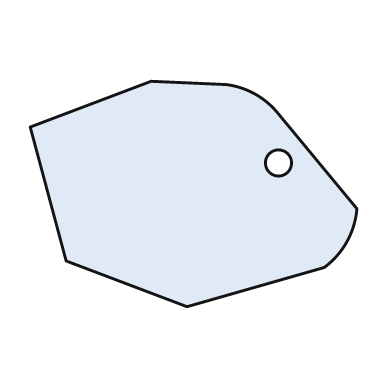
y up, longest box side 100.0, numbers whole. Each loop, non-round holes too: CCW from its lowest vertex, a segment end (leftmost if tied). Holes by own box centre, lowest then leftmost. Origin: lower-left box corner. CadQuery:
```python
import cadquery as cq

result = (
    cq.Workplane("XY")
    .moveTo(48.0, 0.0)
    .lineTo(90.0, 12.0)
    .threePointArc((97.0, 20.0), (100.0, 30.0))
    .lineTo(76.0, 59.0)
    .threePointArc((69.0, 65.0), (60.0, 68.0))
    .lineTo(37.0, 69.0)
    .lineTo(0.0, 55.0)
    .lineTo(11.0, 14.0)
    .close()
    .moveTo(76.0, 44.0)
    .circle(4.0)
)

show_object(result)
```